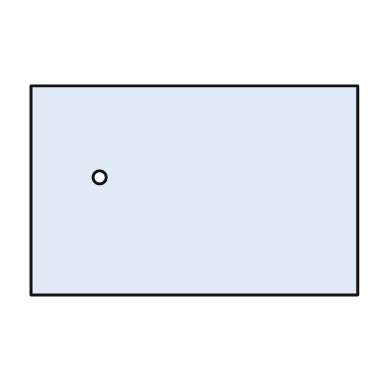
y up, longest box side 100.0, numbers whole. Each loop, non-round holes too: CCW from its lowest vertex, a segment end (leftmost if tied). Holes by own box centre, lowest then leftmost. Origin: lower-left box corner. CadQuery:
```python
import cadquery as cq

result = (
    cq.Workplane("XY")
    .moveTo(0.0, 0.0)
    .lineTo(100.0, 0.0)
    .lineTo(100.0, 64.0)
    .lineTo(0.0, 64.0)
    .close()
    .moveTo(21.0, 36.0)
    .circle(2.0)
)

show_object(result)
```